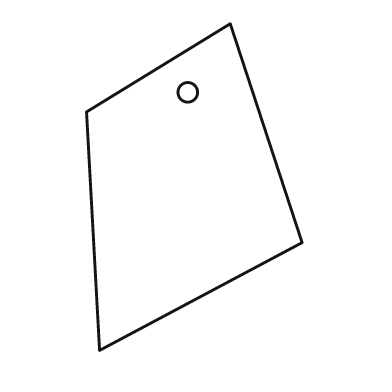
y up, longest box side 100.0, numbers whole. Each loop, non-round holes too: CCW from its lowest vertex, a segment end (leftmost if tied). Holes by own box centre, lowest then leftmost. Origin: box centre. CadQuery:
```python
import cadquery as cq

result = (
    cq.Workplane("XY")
    .moveTo(-29.0, -50.0)
    .lineTo(33.0, -17.0)
    .lineTo(11.0, 50.0)
    .lineTo(-33.0, 23.0)
    .close()
    .moveTo(-2.0, 29.0)
    .circle(3.0)
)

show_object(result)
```